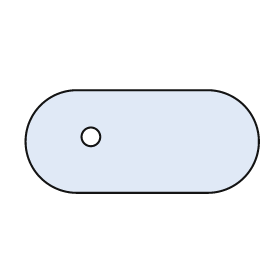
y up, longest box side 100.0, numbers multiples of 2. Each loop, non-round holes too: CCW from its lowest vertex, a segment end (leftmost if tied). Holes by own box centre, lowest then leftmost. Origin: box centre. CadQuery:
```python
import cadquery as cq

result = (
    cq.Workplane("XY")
    .moveTo(-28.0, -22.0)
    .lineTo(28.0, -22.0)
    .threePointArc((50.0, 0.0), (28.0, 22.0))
    .lineTo(-28.0, 22.0)
    .threePointArc((-50.0, 0.0), (-28.0, -22.0))
    .close()
    .moveTo(-22.0, 2.0)
    .circle(4.0)
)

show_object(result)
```